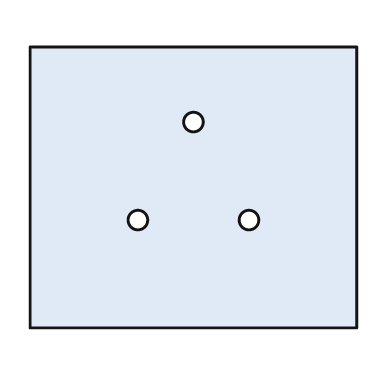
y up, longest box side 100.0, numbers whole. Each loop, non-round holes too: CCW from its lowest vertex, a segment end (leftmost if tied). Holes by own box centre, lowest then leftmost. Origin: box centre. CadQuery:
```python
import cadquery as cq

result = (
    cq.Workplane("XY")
    .moveTo(-50.0, -43.0)
    .lineTo(50.0, -43.0)
    .lineTo(50.0, 43.0)
    .lineTo(-50.0, 43.0)
    .close()
    .moveTo(-17.0, -10.0)
    .circle(3.0)
    .moveTo(17.0, -10.0)
    .circle(3.0)
    .moveTo(0.0, 20.0)
    .circle(3.0)
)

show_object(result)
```